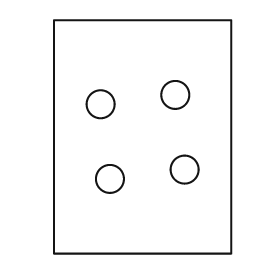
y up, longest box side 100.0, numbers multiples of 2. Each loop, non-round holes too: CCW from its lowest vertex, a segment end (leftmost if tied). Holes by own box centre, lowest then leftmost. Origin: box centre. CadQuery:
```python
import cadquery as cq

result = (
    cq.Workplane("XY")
    .moveTo(-38.0, -50.0)
    .lineTo(38.0, -50.0)
    .lineTo(38.0, 50.0)
    .lineTo(-38.0, 50.0)
    .close()
    .moveTo(-14.0, -18.0)
    .circle(6.0)
    .moveTo(18.0, -14.0)
    .circle(6.0)
    .moveTo(-18.0, 14.0)
    .circle(6.0)
    .moveTo(14.0, 18.0)
    .circle(6.0)
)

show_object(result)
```